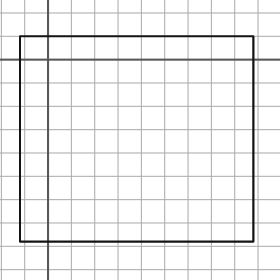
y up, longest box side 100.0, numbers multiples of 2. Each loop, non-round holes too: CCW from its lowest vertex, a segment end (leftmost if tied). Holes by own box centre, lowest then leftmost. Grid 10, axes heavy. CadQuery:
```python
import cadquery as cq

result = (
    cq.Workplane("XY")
    .moveTo(-12.0, -78.0)
    .lineTo(88.0, -78.0)
    .lineTo(88.0, 10.0)
    .lineTo(-12.0, 10.0)
    .close()
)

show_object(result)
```